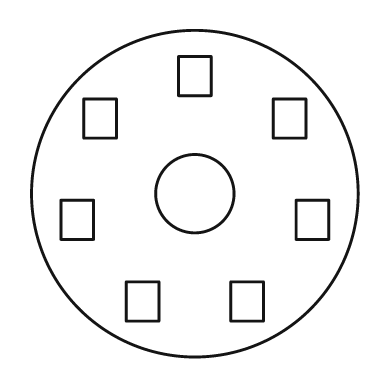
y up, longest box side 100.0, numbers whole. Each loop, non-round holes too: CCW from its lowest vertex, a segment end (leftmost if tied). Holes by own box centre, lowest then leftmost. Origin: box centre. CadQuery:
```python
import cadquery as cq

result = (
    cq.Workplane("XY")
    .moveTo(0.0, 0.0)
    .circle(50.0)
    .moveTo(-21.0, -39.0)
    .lineTo(-11.0, -39.0)
    .lineTo(-11.0, -27.0)
    .lineTo(-21.0, -27.0)
    .close()
    .moveTo(11.0, -39.0)
    .lineTo(21.0, -39.0)
    .lineTo(21.0, -27.0)
    .lineTo(11.0, -27.0)
    .close()
    .moveTo(-41.0, -14.0)
    .lineTo(-31.0, -14.0)
    .lineTo(-31.0, -2.0)
    .lineTo(-41.0, -2.0)
    .close()
    .moveTo(31.0, -14.0)
    .lineTo(41.0, -14.0)
    .lineTo(41.0, -2.0)
    .lineTo(31.0, -2.0)
    .close()
    .moveTo(0.0, 0.0)
    .circle(12.0)
    .moveTo(-34.0, 17.0)
    .lineTo(-24.0, 17.0)
    .lineTo(-24.0, 29.0)
    .lineTo(-34.0, 29.0)
    .close()
    .moveTo(24.0, 17.0)
    .lineTo(34.0, 17.0)
    .lineTo(34.0, 29.0)
    .lineTo(24.0, 29.0)
    .close()
    .moveTo(-5.0, 30.0)
    .lineTo(5.0, 30.0)
    .lineTo(5.0, 42.0)
    .lineTo(-5.0, 42.0)
    .close()
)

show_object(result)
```